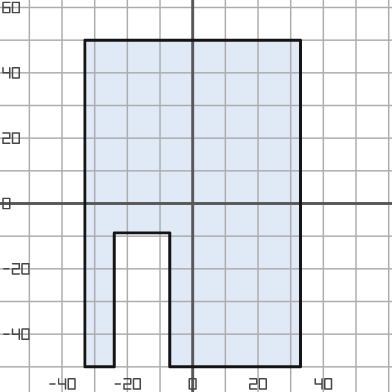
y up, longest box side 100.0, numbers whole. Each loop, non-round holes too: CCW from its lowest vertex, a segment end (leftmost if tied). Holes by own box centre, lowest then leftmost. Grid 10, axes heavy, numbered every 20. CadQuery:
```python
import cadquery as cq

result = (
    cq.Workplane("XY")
    .moveTo(-33.0, -50.0)
    .lineTo(-24.0, -50.0)
    .lineTo(-24.0, -9.0)
    .lineTo(-7.0, -9.0)
    .lineTo(-7.0, -50.0)
    .lineTo(33.0, -50.0)
    .lineTo(33.0, 50.0)
    .lineTo(-33.0, 50.0)
    .close()
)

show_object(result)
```